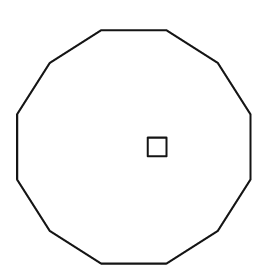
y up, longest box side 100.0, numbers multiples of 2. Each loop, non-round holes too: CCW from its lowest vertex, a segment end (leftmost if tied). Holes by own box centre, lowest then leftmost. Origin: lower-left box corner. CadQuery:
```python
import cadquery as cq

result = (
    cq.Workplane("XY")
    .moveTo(36.0, 0.0)
    .lineTo(64.0, 0.0)
    .lineTo(86.0, 14.0)
    .lineTo(100.0, 36.0)
    .lineTo(100.0, 64.0)
    .lineTo(86.0, 86.0)
    .lineTo(64.0, 100.0)
    .lineTo(36.0, 100.0)
    .lineTo(14.0, 86.0)
    .lineTo(0.0, 64.0)
    .lineTo(0.0, 36.0)
    .lineTo(14.0, 14.0)
    .close()
    .moveTo(56.0, 46.0)
    .lineTo(64.0, 46.0)
    .lineTo(64.0, 54.0)
    .lineTo(56.0, 54.0)
    .close()
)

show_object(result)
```